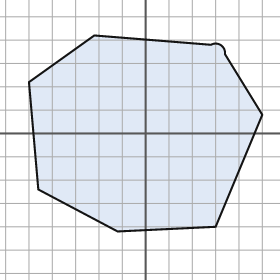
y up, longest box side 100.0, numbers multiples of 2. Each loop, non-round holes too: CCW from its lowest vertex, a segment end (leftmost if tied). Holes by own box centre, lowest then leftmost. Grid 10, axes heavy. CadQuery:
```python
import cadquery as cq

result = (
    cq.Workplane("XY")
    .moveTo(-12.0, -42.0)
    .lineTo(30.0, -40.0)
    .lineTo(50.0, 8.0)
    .lineTo(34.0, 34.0)
    .threePointArc((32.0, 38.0), (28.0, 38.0))
    .lineTo(-22.0, 42.0)
    .lineTo(-50.0, 22.0)
    .lineTo(-46.0, -24.0)
    .close()
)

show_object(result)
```